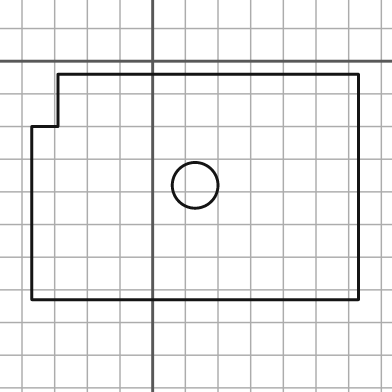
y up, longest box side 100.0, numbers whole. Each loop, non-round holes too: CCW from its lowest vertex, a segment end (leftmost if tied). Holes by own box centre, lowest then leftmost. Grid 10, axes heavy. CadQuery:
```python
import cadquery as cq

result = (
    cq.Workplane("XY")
    .moveTo(-37.0, -73.0)
    .lineTo(63.0, -73.0)
    .lineTo(63.0, -4.0)
    .lineTo(-29.0, -4.0)
    .lineTo(-29.0, -20.0)
    .lineTo(-37.0, -20.0)
    .close()
    .moveTo(13.0, -38.0)
    .circle(7.0)
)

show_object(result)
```